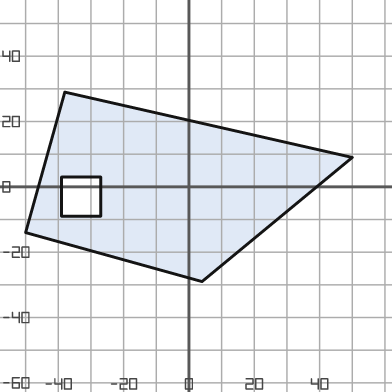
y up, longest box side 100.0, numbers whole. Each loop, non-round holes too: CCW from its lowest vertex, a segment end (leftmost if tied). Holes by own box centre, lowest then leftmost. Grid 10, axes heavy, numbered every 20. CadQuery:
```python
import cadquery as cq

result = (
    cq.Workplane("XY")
    .moveTo(4.0, -29.0)
    .lineTo(50.0, 9.0)
    .lineTo(-38.0, 29.0)
    .lineTo(-50.0, -14.0)
    .close()
    .moveTo(-39.0, -9.0)
    .lineTo(-27.0, -9.0)
    .lineTo(-27.0, 3.0)
    .lineTo(-39.0, 3.0)
    .close()
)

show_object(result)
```